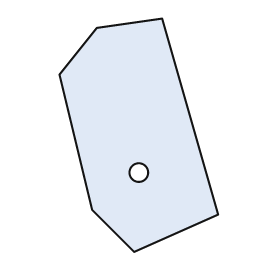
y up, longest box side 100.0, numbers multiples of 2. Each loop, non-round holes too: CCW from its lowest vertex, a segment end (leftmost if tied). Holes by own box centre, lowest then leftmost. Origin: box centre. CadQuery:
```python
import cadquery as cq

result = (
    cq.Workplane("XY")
    .moveTo(-2.0, -50.0)
    .lineTo(34.0, -34.0)
    .lineTo(10.0, 50.0)
    .lineTo(-18.0, 46.0)
    .lineTo(-34.0, 26.0)
    .lineTo(-20.0, -32.0)
    .close()
    .moveTo(0.0, -16.0)
    .circle(4.0)
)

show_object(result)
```